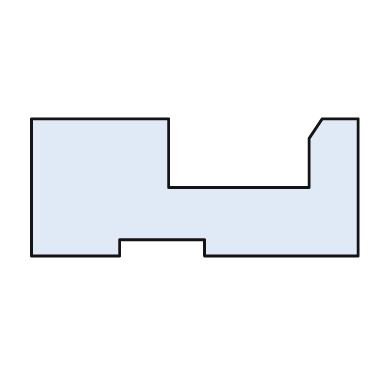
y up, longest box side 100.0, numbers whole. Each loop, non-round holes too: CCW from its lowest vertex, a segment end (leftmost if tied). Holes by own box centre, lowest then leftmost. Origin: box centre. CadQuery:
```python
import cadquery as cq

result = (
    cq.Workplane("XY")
    .moveTo(-50.0, -21.0)
    .lineTo(-23.0, -21.0)
    .lineTo(-23.0, -16.0)
    .lineTo(3.0, -16.0)
    .lineTo(3.0, -21.0)
    .lineTo(50.0, -21.0)
    .lineTo(50.0, 21.0)
    .lineTo(39.0, 21.0)
    .lineTo(35.0, 15.0)
    .lineTo(35.0, 0.0)
    .lineTo(-8.0, 0.0)
    .lineTo(-8.0, 21.0)
    .lineTo(-50.0, 21.0)
    .close()
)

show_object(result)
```